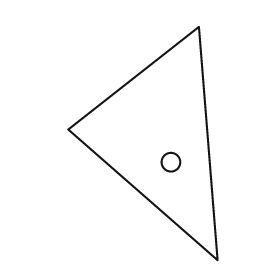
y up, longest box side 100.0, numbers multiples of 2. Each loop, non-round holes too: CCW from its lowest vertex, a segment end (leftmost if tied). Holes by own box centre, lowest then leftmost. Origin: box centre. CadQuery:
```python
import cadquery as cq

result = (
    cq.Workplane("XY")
    .moveTo(32.0, -50.0)
    .lineTo(24.0, 50.0)
    .lineTo(-32.0, 6.0)
    .close()
    .moveTo(12.0, -8.0)
    .circle(4.0)
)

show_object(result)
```